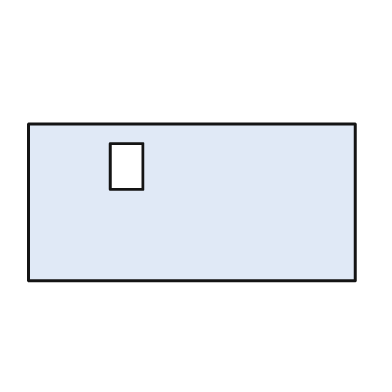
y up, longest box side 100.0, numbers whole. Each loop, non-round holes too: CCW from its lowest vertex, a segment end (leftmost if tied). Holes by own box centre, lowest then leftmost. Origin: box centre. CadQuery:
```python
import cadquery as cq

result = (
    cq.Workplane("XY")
    .moveTo(-50.0, -24.0)
    .lineTo(50.0, -24.0)
    .lineTo(50.0, 24.0)
    .lineTo(-50.0, 24.0)
    .close()
    .moveTo(-25.0, 4.0)
    .lineTo(-15.0, 4.0)
    .lineTo(-15.0, 18.0)
    .lineTo(-25.0, 18.0)
    .close()
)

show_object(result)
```